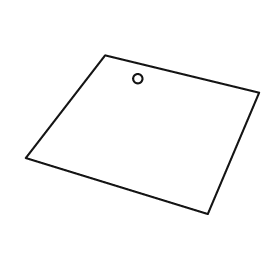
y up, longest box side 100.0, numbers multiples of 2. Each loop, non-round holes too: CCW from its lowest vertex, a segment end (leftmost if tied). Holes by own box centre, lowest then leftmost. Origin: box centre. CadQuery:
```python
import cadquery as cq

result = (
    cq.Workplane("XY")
    .moveTo(28.0, -34.0)
    .lineTo(50.0, 18.0)
    .lineTo(-16.0, 34.0)
    .lineTo(-50.0, -10.0)
    .close()
    .moveTo(-2.0, 24.0)
    .circle(2.0)
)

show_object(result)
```